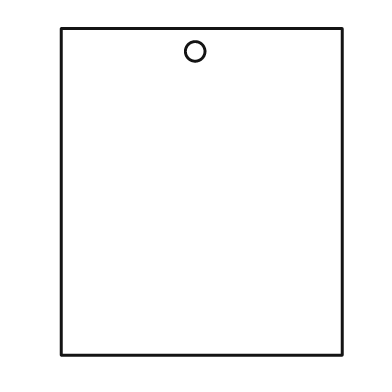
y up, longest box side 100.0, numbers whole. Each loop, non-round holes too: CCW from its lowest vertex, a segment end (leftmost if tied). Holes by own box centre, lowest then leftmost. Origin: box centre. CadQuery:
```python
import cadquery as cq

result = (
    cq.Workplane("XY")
    .moveTo(-43.0, -50.0)
    .lineTo(43.0, -50.0)
    .lineTo(43.0, 50.0)
    .lineTo(-43.0, 50.0)
    .close()
    .moveTo(-2.0, 43.0)
    .circle(3.0)
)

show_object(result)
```